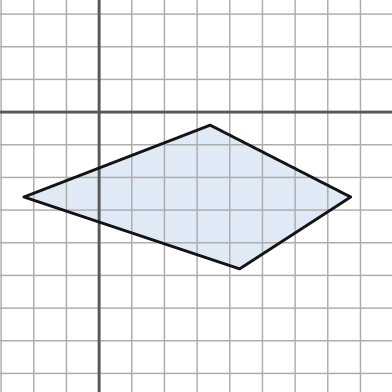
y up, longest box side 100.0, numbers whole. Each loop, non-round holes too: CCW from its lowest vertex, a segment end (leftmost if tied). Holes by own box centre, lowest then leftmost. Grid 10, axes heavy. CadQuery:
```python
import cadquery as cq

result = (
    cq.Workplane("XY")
    .moveTo(43.0, -48.0)
    .lineTo(77.0, -26.0)
    .lineTo(34.0, -4.0)
    .lineTo(-23.0, -26.0)
    .close()
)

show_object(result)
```